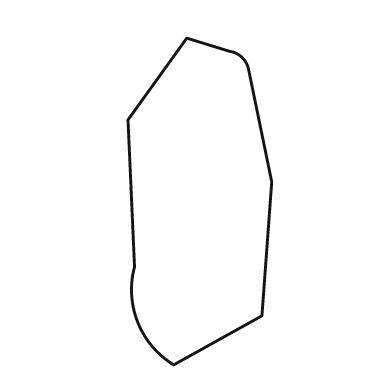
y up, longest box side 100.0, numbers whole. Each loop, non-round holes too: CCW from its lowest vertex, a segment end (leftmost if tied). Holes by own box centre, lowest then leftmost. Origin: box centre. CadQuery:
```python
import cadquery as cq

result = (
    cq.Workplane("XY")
    .moveTo(-8.0, -50.0)
    .lineTo(19.0, -35.0)
    .lineTo(22.0, 6.0)
    .lineTo(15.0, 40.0)
    .threePointArc((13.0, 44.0), (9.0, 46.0))
    .lineTo(-4.0, 50.0)
    .lineTo(-22.0, 25.0)
    .lineTo(-20.0, -20.0)
    .threePointArc((-19.0, -37.0), (-8.0, -50.0))
    .close()
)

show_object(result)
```